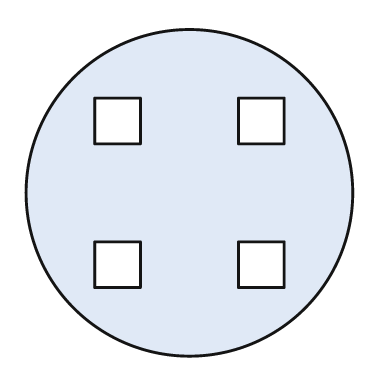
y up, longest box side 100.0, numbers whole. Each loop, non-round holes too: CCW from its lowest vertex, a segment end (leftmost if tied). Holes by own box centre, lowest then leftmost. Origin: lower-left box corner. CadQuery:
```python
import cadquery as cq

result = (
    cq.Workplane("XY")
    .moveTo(50.0, 50.0)
    .circle(50.0)
    .moveTo(21.0, 21.0)
    .lineTo(35.0, 21.0)
    .lineTo(35.0, 35.0)
    .lineTo(21.0, 35.0)
    .close()
    .moveTo(65.0, 21.0)
    .lineTo(79.0, 21.0)
    .lineTo(79.0, 35.0)
    .lineTo(65.0, 35.0)
    .close()
    .moveTo(21.0, 65.0)
    .lineTo(35.0, 65.0)
    .lineTo(35.0, 79.0)
    .lineTo(21.0, 79.0)
    .close()
    .moveTo(65.0, 65.0)
    .lineTo(79.0, 65.0)
    .lineTo(79.0, 79.0)
    .lineTo(65.0, 79.0)
    .close()
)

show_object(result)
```